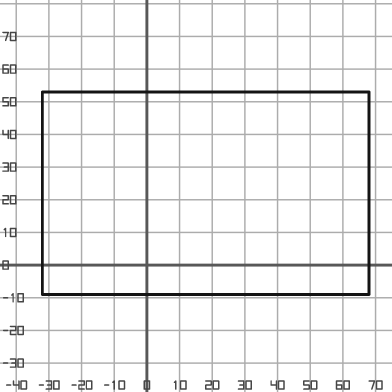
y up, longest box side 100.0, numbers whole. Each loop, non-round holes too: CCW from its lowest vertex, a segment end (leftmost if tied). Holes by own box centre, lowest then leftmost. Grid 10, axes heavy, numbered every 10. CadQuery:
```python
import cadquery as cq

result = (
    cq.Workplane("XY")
    .moveTo(-32.0, -9.0)
    .lineTo(68.0, -9.0)
    .lineTo(68.0, 53.0)
    .lineTo(-32.0, 53.0)
    .close()
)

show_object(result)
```